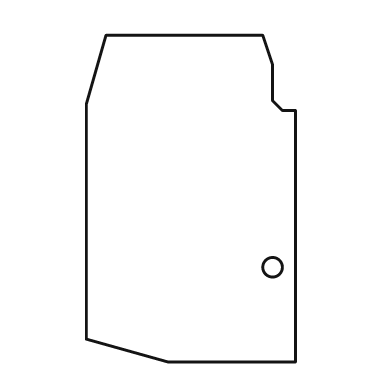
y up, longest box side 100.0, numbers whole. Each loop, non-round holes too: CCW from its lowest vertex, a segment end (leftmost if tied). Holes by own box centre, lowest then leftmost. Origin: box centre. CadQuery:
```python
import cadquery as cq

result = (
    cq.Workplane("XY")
    .moveTo(-7.0, -50.0)
    .lineTo(32.0, -50.0)
    .lineTo(32.0, 27.0)
    .lineTo(28.0, 27.0)
    .lineTo(25.0, 30.0)
    .lineTo(25.0, 41.0)
    .lineTo(22.0, 50.0)
    .lineTo(-26.0, 50.0)
    .lineTo(-32.0, 29.0)
    .lineTo(-32.0, -43.0)
    .close()
    .moveTo(25.0, -21.0)
    .circle(3.0)
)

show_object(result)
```